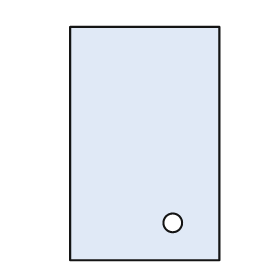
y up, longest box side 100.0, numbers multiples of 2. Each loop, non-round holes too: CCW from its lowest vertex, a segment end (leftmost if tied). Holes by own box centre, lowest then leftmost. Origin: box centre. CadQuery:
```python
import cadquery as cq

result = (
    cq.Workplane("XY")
    .moveTo(-32.0, -50.0)
    .lineTo(32.0, -50.0)
    .lineTo(32.0, 50.0)
    .lineTo(-32.0, 50.0)
    .close()
    .moveTo(12.0, -34.0)
    .circle(4.0)
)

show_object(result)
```